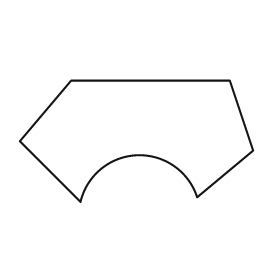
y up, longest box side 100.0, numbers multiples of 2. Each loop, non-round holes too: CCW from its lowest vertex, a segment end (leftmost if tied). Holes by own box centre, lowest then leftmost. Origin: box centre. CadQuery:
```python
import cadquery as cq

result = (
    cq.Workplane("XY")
    .moveTo(-24.0, -26.0)
    .threePointArc((0.0, -6.0), (26.0, -24.0))
    .lineTo(50.0, -4.0)
    .lineTo(40.0, 26.0)
    .lineTo(-28.0, 26.0)
    .lineTo(-50.0, 0.0)
    .close()
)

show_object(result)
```